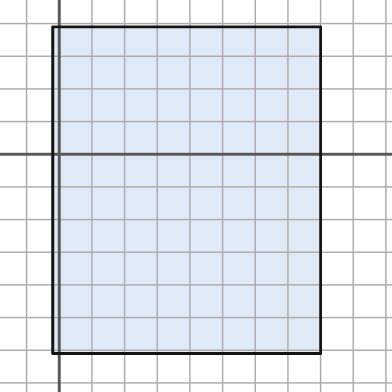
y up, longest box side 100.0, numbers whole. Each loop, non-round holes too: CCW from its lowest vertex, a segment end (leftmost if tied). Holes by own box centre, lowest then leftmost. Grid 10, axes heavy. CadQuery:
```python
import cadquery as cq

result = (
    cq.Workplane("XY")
    .moveTo(-2.0, -61.0)
    .lineTo(80.0, -61.0)
    .lineTo(80.0, 39.0)
    .lineTo(-2.0, 39.0)
    .close()
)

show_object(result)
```